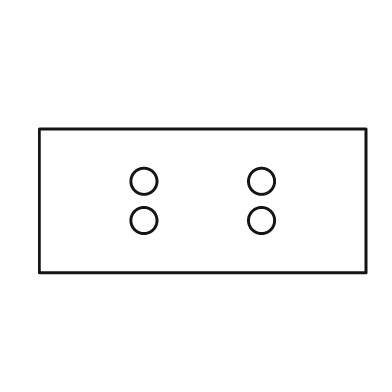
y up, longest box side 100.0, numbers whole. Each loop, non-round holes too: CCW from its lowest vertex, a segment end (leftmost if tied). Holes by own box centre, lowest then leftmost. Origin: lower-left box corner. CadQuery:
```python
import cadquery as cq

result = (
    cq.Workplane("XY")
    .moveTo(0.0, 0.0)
    .lineTo(100.0, 0.0)
    .lineTo(100.0, 44.0)
    .lineTo(0.0, 44.0)
    .close()
    .moveTo(32.0, 16.0)
    .circle(4.0)
    .moveTo(68.0, 16.0)
    .circle(4.0)
    .moveTo(32.0, 28.0)
    .circle(4.0)
    .moveTo(68.0, 28.0)
    .circle(4.0)
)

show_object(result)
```